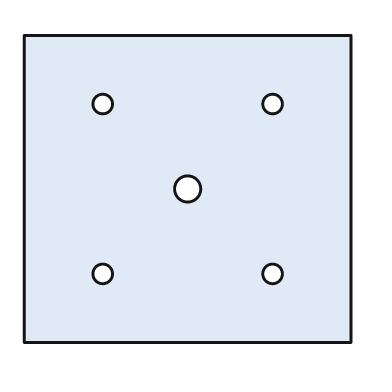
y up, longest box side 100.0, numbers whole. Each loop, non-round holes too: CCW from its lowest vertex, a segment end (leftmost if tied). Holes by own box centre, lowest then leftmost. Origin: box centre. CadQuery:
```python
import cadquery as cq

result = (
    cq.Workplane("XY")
    .moveTo(-50.0, -47.0)
    .lineTo(50.0, -47.0)
    .lineTo(50.0, 47.0)
    .lineTo(-50.0, 47.0)
    .close()
    .moveTo(-26.0, -26.0)
    .circle(3.0)
    .moveTo(26.0, -26.0)
    .circle(3.0)
    .moveTo(0.0, 0.0)
    .circle(4.0)
    .moveTo(-26.0, 26.0)
    .circle(3.0)
    .moveTo(26.0, 26.0)
    .circle(3.0)
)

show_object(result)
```